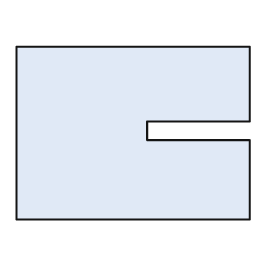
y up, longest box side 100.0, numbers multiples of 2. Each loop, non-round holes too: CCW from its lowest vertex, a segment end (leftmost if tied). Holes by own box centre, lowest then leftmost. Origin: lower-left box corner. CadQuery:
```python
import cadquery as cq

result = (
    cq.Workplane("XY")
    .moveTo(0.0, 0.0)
    .lineTo(100.0, 0.0)
    .lineTo(100.0, 34.0)
    .lineTo(56.0, 34.0)
    .lineTo(56.0, 42.0)
    .lineTo(100.0, 42.0)
    .lineTo(100.0, 74.0)
    .lineTo(0.0, 74.0)
    .close()
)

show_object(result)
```